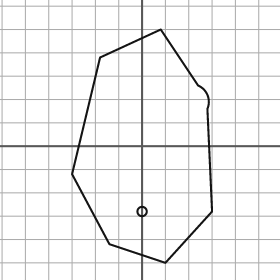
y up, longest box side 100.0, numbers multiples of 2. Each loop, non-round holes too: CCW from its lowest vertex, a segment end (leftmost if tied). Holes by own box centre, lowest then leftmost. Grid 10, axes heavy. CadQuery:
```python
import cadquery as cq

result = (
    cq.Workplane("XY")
    .moveTo(10.0, -50.0)
    .lineTo(30.0, -28.0)
    .lineTo(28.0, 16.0)
    .threePointArc((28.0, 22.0), (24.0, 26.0))
    .lineTo(8.0, 50.0)
    .lineTo(-18.0, 38.0)
    .lineTo(-30.0, -12.0)
    .lineTo(-14.0, -42.0)
    .close()
    .moveTo(0.0, -28.0)
    .circle(2.0)
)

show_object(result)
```